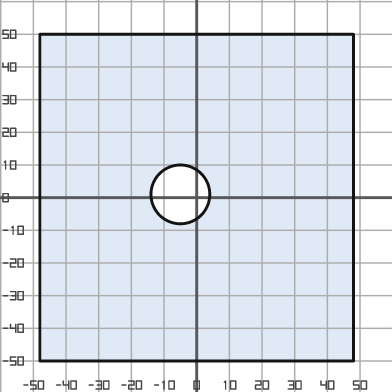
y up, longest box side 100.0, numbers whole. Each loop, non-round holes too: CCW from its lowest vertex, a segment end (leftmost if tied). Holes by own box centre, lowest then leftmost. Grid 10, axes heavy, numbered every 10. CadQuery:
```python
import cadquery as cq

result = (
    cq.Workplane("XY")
    .moveTo(-48.0, -50.0)
    .lineTo(48.0, -50.0)
    .lineTo(48.0, 50.0)
    .lineTo(-48.0, 50.0)
    .close()
    .moveTo(-5.0, 1.0)
    .circle(9.0)
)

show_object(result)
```